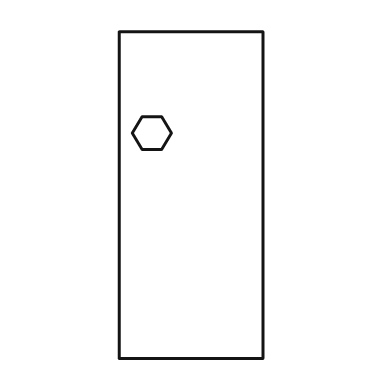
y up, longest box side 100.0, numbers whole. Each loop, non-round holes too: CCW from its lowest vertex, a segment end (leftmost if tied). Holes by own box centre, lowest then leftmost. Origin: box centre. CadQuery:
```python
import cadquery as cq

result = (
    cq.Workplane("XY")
    .moveTo(-22.0, -50.0)
    .lineTo(22.0, -50.0)
    .lineTo(22.0, 50.0)
    .lineTo(-22.0, 50.0)
    .close()
    .moveTo(-15.0, 14.0)
    .lineTo(-9.0, 14.0)
    .lineTo(-6.0, 19.0)
    .lineTo(-9.0, 24.0)
    .lineTo(-15.0, 24.0)
    .lineTo(-18.0, 19.0)
    .close()
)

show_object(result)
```